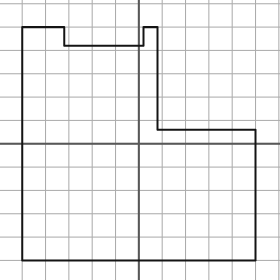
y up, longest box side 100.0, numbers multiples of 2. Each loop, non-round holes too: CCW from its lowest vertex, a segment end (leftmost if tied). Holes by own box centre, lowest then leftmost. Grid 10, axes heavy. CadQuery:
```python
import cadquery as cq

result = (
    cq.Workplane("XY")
    .moveTo(-50.0, -50.0)
    .lineTo(50.0, -50.0)
    .lineTo(50.0, 6.0)
    .lineTo(8.0, 6.0)
    .lineTo(8.0, 50.0)
    .lineTo(2.0, 50.0)
    .lineTo(2.0, 42.0)
    .lineTo(-32.0, 42.0)
    .lineTo(-32.0, 50.0)
    .lineTo(-50.0, 50.0)
    .close()
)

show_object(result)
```